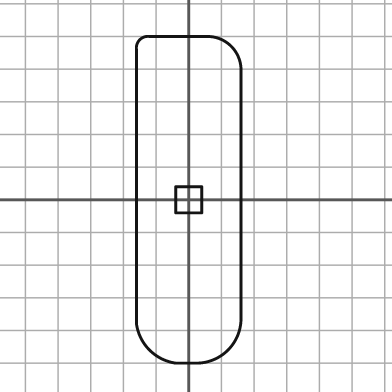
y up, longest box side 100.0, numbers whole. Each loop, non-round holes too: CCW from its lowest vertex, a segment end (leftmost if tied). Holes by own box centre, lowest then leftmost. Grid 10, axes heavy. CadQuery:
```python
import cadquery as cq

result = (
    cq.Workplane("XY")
    .moveTo(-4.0, -50.0)
    .lineTo(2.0, -50.0)
    .threePointArc((12.0, -46.0), (16.0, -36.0))
    .lineTo(16.0, 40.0)
    .threePointArc((13.0, 47.0), (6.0, 50.0))
    .lineTo(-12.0, 50.0)
    .threePointArc((-15.0, 49.0), (-16.0, 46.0))
    .lineTo(-16.0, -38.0)
    .threePointArc((-12.0, -46.0), (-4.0, -50.0))
    .close()
    .moveTo(-4.0, -4.0)
    .lineTo(4.0, -4.0)
    .lineTo(4.0, 4.0)
    .lineTo(-4.0, 4.0)
    .close()
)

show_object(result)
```